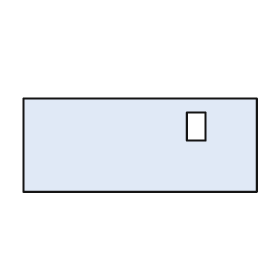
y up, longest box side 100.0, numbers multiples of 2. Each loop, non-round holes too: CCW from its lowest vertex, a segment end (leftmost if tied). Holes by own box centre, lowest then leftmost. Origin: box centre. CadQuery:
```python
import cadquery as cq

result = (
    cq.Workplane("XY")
    .moveTo(-50.0, -20.0)
    .lineTo(50.0, -20.0)
    .lineTo(50.0, 20.0)
    .lineTo(-50.0, 20.0)
    .close()
    .moveTo(20.0, 2.0)
    .lineTo(28.0, 2.0)
    .lineTo(28.0, 14.0)
    .lineTo(20.0, 14.0)
    .close()
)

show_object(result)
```